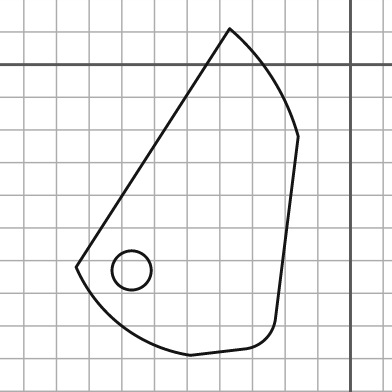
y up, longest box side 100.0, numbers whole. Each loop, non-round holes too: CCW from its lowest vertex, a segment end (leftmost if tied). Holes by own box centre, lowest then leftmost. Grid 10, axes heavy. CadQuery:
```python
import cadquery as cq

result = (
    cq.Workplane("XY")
    .moveTo(-49.0, -89.0)
    .lineTo(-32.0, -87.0)
    .threePointArc((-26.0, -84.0), (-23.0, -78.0))
    .lineTo(-16.0, -22.0)
    .threePointArc((-24.0, -4.0), (-37.0, 11.0))
    .lineTo(-84.0, -62.0)
    .threePointArc((-70.0, -80.0), (-49.0, -89.0))
    .close()
    .moveTo(-67.0, -63.0)
    .circle(6.0)
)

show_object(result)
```